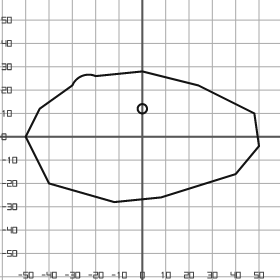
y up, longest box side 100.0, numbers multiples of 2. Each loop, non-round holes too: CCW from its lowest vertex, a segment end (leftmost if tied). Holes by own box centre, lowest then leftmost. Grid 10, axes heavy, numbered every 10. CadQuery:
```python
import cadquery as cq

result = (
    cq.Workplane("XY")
    .moveTo(-12.0, -28.0)
    .lineTo(8.0, -26.0)
    .lineTo(40.0, -16.0)
    .lineTo(50.0, -4.0)
    .lineTo(48.0, 10.0)
    .lineTo(24.0, 22.0)
    .lineTo(0.0, 28.0)
    .lineTo(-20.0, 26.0)
    .threePointArc((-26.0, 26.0), (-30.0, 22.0))
    .lineTo(-44.0, 12.0)
    .lineTo(-50.0, 0.0)
    .lineTo(-40.0, -20.0)
    .close()
    .moveTo(0.0, 12.0)
    .circle(2.0)
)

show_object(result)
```